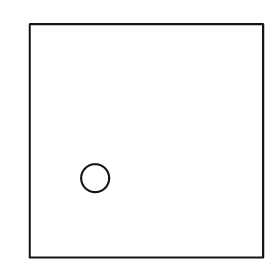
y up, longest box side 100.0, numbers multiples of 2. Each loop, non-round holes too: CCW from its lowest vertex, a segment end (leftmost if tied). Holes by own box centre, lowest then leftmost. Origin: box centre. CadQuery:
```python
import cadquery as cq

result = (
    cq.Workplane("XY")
    .moveTo(-50.0, -50.0)
    .lineTo(50.0, -50.0)
    .lineTo(50.0, 50.0)
    .lineTo(-50.0, 50.0)
    .close()
    .moveTo(-22.0, -16.0)
    .circle(6.0)
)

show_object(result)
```